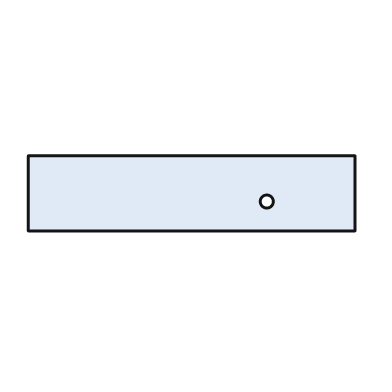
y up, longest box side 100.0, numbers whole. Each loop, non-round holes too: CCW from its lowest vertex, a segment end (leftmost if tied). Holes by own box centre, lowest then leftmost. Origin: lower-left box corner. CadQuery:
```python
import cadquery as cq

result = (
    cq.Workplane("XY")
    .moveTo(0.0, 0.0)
    .lineTo(100.0, 0.0)
    .lineTo(100.0, 23.0)
    .lineTo(0.0, 23.0)
    .close()
    .moveTo(73.0, 9.0)
    .circle(2.0)
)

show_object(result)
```